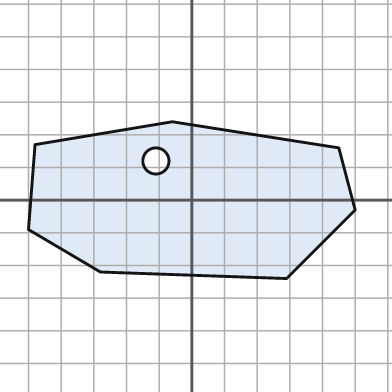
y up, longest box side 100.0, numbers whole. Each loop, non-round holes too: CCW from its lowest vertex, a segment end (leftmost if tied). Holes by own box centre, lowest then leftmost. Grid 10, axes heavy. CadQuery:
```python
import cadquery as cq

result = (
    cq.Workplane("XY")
    .moveTo(29.0, -24.0)
    .lineTo(50.0, -3.0)
    .lineTo(45.0, 16.0)
    .lineTo(-6.0, 24.0)
    .lineTo(-48.0, 17.0)
    .lineTo(-50.0, -9.0)
    .lineTo(-28.0, -22.0)
    .close()
    .moveTo(-11.0, 12.0)
    .circle(4.0)
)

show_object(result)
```